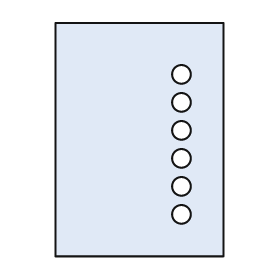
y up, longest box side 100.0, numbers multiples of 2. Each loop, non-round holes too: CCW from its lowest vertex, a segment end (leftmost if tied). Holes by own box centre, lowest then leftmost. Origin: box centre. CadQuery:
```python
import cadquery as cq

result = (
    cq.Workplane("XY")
    .moveTo(-36.0, -50.0)
    .lineTo(36.0, -50.0)
    .lineTo(36.0, 50.0)
    .lineTo(-36.0, 50.0)
    .close()
    .moveTo(18.0, -32.0)
    .circle(4.0)
    .moveTo(18.0, -20.0)
    .circle(4.0)
    .moveTo(18.0, -8.0)
    .circle(4.0)
    .moveTo(18.0, 4.0)
    .circle(4.0)
    .moveTo(18.0, 16.0)
    .circle(4.0)
    .moveTo(18.0, 28.0)
    .circle(4.0)
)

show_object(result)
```